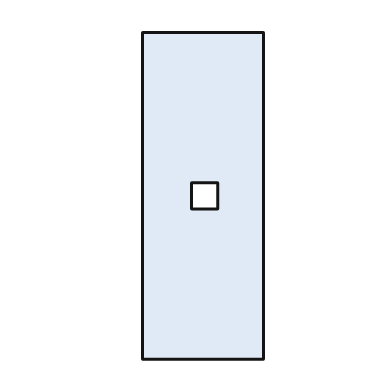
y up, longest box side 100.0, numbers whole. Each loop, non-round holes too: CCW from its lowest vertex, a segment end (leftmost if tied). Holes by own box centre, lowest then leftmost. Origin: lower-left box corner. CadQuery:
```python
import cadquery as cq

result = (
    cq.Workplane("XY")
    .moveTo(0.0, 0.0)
    .lineTo(37.0, 0.0)
    .lineTo(37.0, 100.0)
    .lineTo(0.0, 100.0)
    .close()
    .moveTo(15.0, 46.0)
    .lineTo(23.0, 46.0)
    .lineTo(23.0, 54.0)
    .lineTo(15.0, 54.0)
    .close()
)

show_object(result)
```